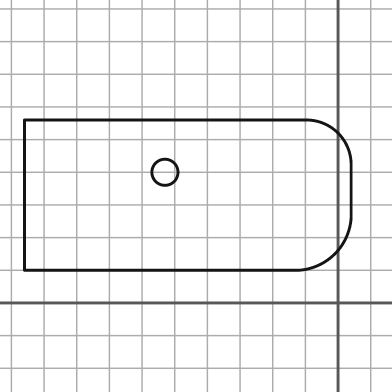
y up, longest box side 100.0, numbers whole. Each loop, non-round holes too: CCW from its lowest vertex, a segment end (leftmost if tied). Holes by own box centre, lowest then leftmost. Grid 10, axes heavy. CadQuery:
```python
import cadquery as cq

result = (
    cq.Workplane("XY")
    .moveTo(-96.0, 10.0)
    .lineTo(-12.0, 10.0)
    .threePointArc((-1.0, 15.0), (4.0, 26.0))
    .lineTo(4.0, 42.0)
    .threePointArc((0.0, 52.0), (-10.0, 56.0))
    .lineTo(-96.0, 56.0)
    .close()
    .moveTo(-53.0, 40.0)
    .circle(4.0)
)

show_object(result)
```